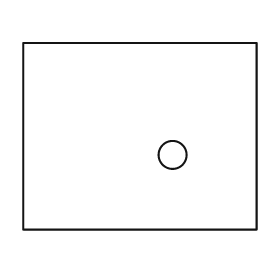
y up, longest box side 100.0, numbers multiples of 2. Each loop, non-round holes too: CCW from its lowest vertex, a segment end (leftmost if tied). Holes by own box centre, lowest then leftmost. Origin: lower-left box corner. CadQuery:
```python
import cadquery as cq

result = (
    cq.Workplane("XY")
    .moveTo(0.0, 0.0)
    .lineTo(100.0, 0.0)
    .lineTo(100.0, 80.0)
    .lineTo(0.0, 80.0)
    .close()
    .moveTo(64.0, 32.0)
    .circle(6.0)
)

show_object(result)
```